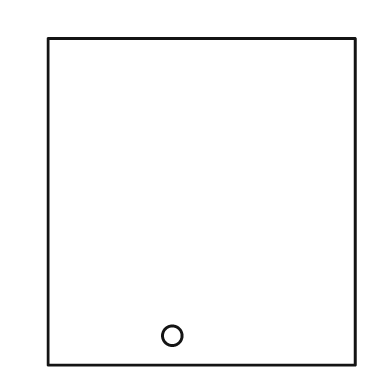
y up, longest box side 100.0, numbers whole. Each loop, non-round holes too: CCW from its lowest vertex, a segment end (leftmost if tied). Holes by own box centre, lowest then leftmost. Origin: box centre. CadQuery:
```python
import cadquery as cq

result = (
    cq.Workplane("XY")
    .moveTo(-47.0, -50.0)
    .lineTo(47.0, -50.0)
    .lineTo(47.0, 50.0)
    .lineTo(-47.0, 50.0)
    .close()
    .moveTo(-9.0, -41.0)
    .circle(3.0)
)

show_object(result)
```